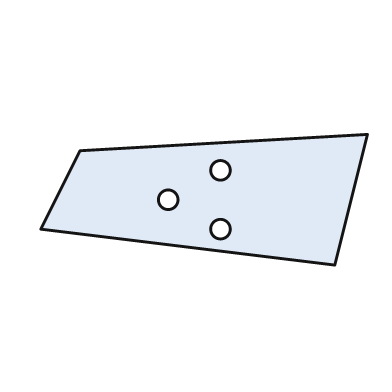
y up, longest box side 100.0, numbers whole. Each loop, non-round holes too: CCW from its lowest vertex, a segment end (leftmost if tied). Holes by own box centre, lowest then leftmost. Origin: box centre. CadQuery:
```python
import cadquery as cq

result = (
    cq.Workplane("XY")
    .moveTo(40.0, -20.0)
    .lineTo(50.0, 20.0)
    .lineTo(-38.0, 15.0)
    .lineTo(-50.0, -9.0)
    .close()
    .moveTo(5.0, -9.0)
    .circle(3.0)
    .moveTo(-11.0, 0.0)
    .circle(3.0)
    .moveTo(5.0, 9.0)
    .circle(3.0)
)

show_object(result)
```